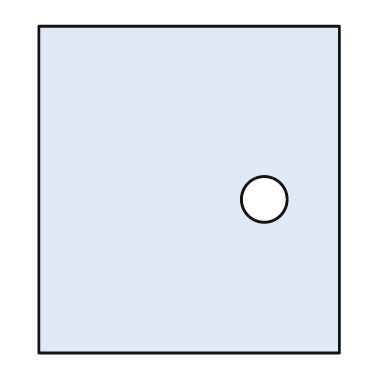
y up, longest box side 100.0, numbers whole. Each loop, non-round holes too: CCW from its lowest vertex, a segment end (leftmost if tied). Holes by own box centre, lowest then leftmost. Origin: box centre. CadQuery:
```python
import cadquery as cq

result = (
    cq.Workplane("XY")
    .moveTo(-46.0, -50.0)
    .lineTo(46.0, -50.0)
    .lineTo(46.0, 50.0)
    .lineTo(-46.0, 50.0)
    .close()
    .moveTo(23.0, -3.0)
    .circle(7.0)
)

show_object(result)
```